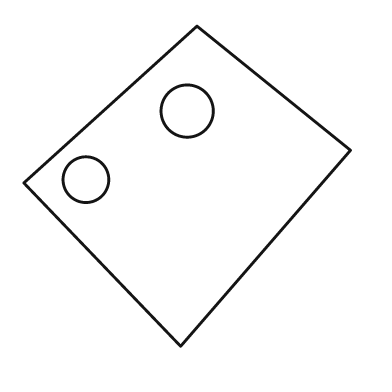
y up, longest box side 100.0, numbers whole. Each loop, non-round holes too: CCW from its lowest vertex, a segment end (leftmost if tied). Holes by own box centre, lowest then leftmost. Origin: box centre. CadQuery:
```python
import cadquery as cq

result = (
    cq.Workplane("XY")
    .moveTo(-2.0, -49.0)
    .lineTo(50.0, 11.0)
    .lineTo(3.0, 49.0)
    .lineTo(-50.0, 1.0)
    .close()
    .moveTo(-31.0, 2.0)
    .circle(7.0)
    .moveTo(0.0, 23.0)
    .circle(8.0)
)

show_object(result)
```